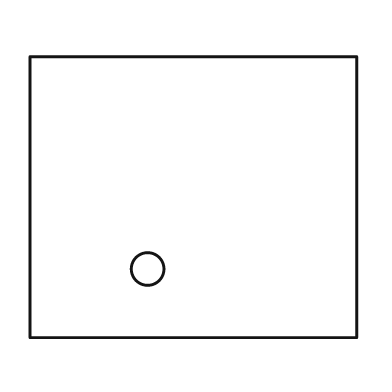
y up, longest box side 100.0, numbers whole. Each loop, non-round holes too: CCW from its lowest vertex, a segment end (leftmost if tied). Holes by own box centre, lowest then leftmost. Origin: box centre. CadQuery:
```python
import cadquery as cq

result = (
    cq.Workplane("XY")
    .moveTo(-50.0, -43.0)
    .lineTo(50.0, -43.0)
    .lineTo(50.0, 43.0)
    .lineTo(-50.0, 43.0)
    .close()
    .moveTo(-14.0, -22.0)
    .circle(5.0)
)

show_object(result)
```